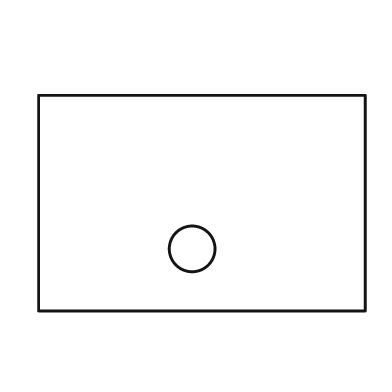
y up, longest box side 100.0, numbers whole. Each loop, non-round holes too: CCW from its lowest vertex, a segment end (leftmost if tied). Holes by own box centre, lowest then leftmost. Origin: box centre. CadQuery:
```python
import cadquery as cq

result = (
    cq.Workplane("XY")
    .moveTo(-50.0, -33.0)
    .lineTo(50.0, -33.0)
    .lineTo(50.0, 33.0)
    .lineTo(-50.0, 33.0)
    .close()
    .moveTo(-3.0, -14.0)
    .circle(7.0)
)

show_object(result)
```